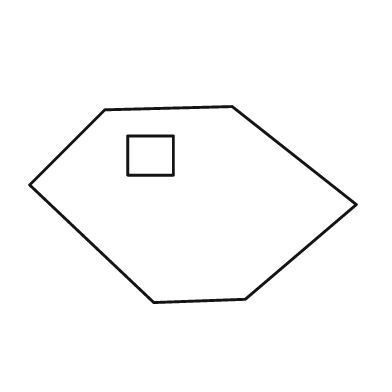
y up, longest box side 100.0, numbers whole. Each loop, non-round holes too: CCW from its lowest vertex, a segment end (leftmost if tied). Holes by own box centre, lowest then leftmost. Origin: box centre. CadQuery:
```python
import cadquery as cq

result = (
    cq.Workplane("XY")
    .moveTo(-12.0, -30.0)
    .lineTo(16.0, -29.0)
    .lineTo(50.0, 0.0)
    .lineTo(12.0, 30.0)
    .lineTo(-27.0, 29.0)
    .lineTo(-50.0, 6.0)
    .close()
    .moveTo(-20.0, 9.0)
    .lineTo(-6.0, 9.0)
    .lineTo(-6.0, 21.0)
    .lineTo(-20.0, 21.0)
    .close()
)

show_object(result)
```